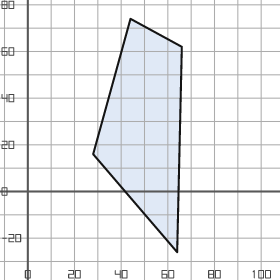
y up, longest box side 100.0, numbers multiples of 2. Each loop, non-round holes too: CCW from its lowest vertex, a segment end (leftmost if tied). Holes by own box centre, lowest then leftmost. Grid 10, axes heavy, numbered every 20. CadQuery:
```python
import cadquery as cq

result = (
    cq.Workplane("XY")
    .moveTo(64.0, -26.0)
    .lineTo(66.0, 62.0)
    .lineTo(44.0, 74.0)
    .lineTo(28.0, 16.0)
    .close()
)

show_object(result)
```